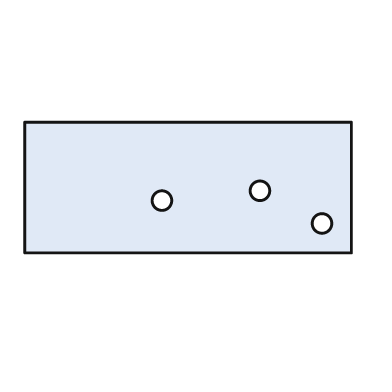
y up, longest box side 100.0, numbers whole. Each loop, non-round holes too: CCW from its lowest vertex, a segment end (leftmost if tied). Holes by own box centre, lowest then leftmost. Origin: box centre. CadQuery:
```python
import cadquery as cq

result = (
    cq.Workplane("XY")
    .moveTo(-50.0, -20.0)
    .lineTo(50.0, -20.0)
    .lineTo(50.0, 20.0)
    .lineTo(-50.0, 20.0)
    .close()
    .moveTo(41.0, -11.0)
    .circle(3.0)
    .moveTo(-8.0, -4.0)
    .circle(3.0)
    .moveTo(22.0, -1.0)
    .circle(3.0)
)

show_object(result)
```